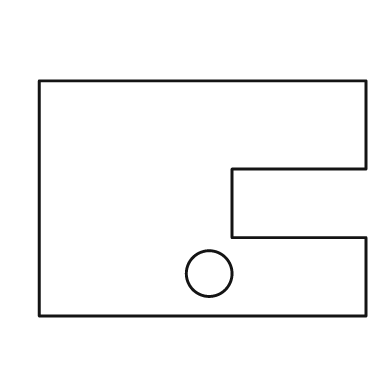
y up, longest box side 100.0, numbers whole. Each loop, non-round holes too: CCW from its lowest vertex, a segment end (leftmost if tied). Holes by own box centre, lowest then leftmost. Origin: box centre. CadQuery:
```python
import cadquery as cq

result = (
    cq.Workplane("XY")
    .moveTo(-50.0, -36.0)
    .lineTo(50.0, -36.0)
    .lineTo(50.0, -12.0)
    .lineTo(9.0, -12.0)
    .lineTo(9.0, 9.0)
    .lineTo(50.0, 9.0)
    .lineTo(50.0, 36.0)
    .lineTo(-50.0, 36.0)
    .close()
    .moveTo(2.0, -23.0)
    .circle(7.0)
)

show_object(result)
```